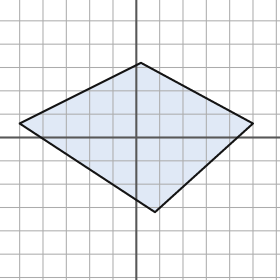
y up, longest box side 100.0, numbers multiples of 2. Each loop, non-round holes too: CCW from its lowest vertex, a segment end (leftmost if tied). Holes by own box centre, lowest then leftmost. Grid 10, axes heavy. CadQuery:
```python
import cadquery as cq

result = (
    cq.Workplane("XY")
    .moveTo(8.0, -32.0)
    .lineTo(50.0, 6.0)
    .lineTo(2.0, 32.0)
    .lineTo(-50.0, 6.0)
    .close()
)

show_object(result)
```